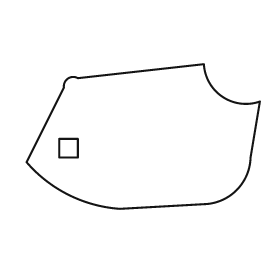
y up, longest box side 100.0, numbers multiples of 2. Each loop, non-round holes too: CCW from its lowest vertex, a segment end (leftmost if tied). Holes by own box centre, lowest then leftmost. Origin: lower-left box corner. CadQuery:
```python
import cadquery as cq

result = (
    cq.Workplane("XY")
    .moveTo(40.0, 0.0)
    .lineTo(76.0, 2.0)
    .threePointArc((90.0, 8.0), (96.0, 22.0))
    .lineTo(100.0, 46.0)
    .threePointArc((84.0, 48.0), (76.0, 62.0))
    .lineTo(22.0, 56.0)
    .threePointArc((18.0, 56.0), (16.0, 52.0))
    .lineTo(0.0, 20.0)
    .threePointArc((18.0, 6.0), (40.0, 0.0))
    .close()
    .moveTo(14.0, 22.0)
    .lineTo(22.0, 22.0)
    .lineTo(22.0, 30.0)
    .lineTo(14.0, 30.0)
    .close()
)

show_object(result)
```